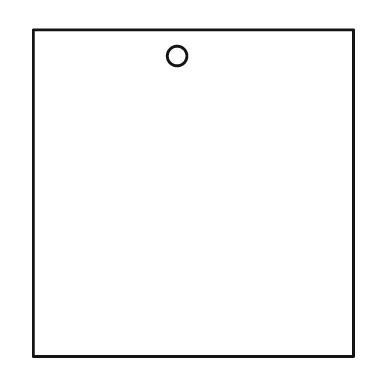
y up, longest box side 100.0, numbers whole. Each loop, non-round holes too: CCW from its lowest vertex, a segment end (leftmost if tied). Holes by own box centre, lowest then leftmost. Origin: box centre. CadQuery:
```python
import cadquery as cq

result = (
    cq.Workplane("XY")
    .moveTo(-49.0, -50.0)
    .lineTo(49.0, -50.0)
    .lineTo(49.0, 50.0)
    .lineTo(-49.0, 50.0)
    .close()
    .moveTo(-5.0, 42.0)
    .circle(3.0)
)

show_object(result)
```